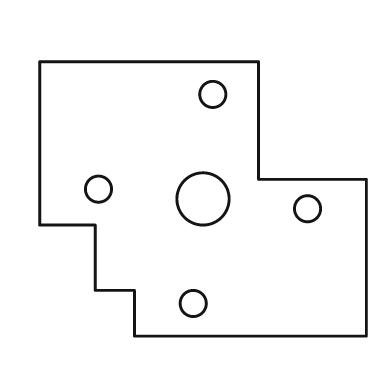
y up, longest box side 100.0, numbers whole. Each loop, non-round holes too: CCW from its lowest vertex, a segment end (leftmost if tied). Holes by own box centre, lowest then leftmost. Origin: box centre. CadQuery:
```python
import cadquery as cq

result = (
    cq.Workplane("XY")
    .moveTo(-21.0, -42.0)
    .lineTo(50.0, -42.0)
    .lineTo(50.0, 6.0)
    .lineTo(17.0, 6.0)
    .lineTo(17.0, 42.0)
    .lineTo(-50.0, 42.0)
    .lineTo(-50.0, -8.0)
    .lineTo(-33.0, -8.0)
    .lineTo(-33.0, -28.0)
    .lineTo(-21.0, -28.0)
    .close()
    .moveTo(-3.0, -32.0)
    .circle(4.0)
    .moveTo(32.0, -3.0)
    .circle(4.0)
    .moveTo(0.0, 0.0)
    .circle(8.0)
    .moveTo(-32.0, 3.0)
    .circle(4.0)
    .moveTo(3.0, 32.0)
    .circle(4.0)
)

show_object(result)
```